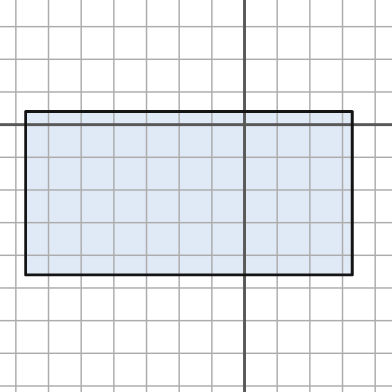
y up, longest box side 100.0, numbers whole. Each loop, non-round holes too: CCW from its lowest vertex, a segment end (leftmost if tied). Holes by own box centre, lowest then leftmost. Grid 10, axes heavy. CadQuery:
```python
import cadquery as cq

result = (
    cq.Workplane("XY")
    .moveTo(-67.0, -46.0)
    .lineTo(33.0, -46.0)
    .lineTo(33.0, 4.0)
    .lineTo(-67.0, 4.0)
    .close()
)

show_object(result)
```